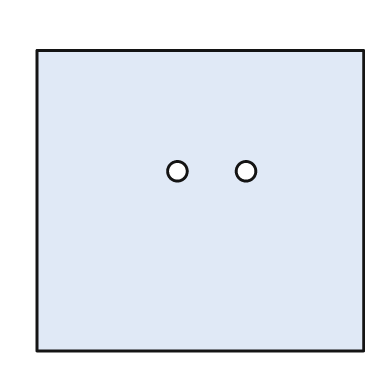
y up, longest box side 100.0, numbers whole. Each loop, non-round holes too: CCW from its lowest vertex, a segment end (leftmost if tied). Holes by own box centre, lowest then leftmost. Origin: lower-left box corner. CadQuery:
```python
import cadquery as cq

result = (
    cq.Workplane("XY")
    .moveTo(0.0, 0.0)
    .lineTo(100.0, 0.0)
    .lineTo(100.0, 92.0)
    .lineTo(0.0, 92.0)
    .close()
    .moveTo(43.0, 55.0)
    .circle(3.0)
    .moveTo(64.0, 55.0)
    .circle(3.0)
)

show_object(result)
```